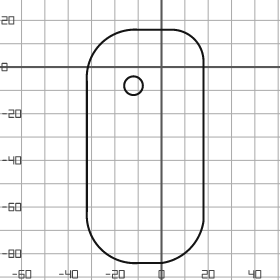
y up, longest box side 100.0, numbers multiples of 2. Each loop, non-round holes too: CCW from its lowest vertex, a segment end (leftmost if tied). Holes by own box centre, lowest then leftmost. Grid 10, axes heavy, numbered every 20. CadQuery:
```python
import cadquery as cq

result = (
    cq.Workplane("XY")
    .moveTo(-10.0, -84.0)
    .lineTo(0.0, -84.0)
    .threePointArc((12.0, -78.0), (18.0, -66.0))
    .lineTo(18.0, 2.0)
    .threePointArc((14.0, 12.0), (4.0, 16.0))
    .lineTo(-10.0, 16.0)
    .threePointArc((-26.0, 10.0), (-32.0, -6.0))
    .lineTo(-32.0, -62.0)
    .threePointArc((-26.0, -78.0), (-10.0, -84.0))
    .close()
    .moveTo(-12.0, -8.0)
    .circle(4.0)
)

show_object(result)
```